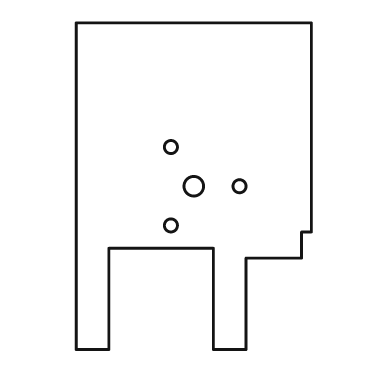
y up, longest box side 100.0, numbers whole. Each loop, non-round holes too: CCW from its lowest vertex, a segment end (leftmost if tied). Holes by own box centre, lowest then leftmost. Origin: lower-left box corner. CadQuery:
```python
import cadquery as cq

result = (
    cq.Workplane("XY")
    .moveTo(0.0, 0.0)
    .lineTo(10.0, 0.0)
    .lineTo(10.0, 31.0)
    .lineTo(42.0, 31.0)
    .lineTo(42.0, 0.0)
    .lineTo(52.0, 0.0)
    .lineTo(52.0, 28.0)
    .lineTo(69.0, 28.0)
    .lineTo(69.0, 36.0)
    .lineTo(72.0, 36.0)
    .lineTo(72.0, 100.0)
    .lineTo(0.0, 100.0)
    .close()
    .moveTo(29.0, 38.0)
    .circle(2.0)
    .moveTo(36.0, 50.0)
    .circle(3.0)
    .moveTo(50.0, 50.0)
    .circle(2.0)
    .moveTo(29.0, 62.0)
    .circle(2.0)
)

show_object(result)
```